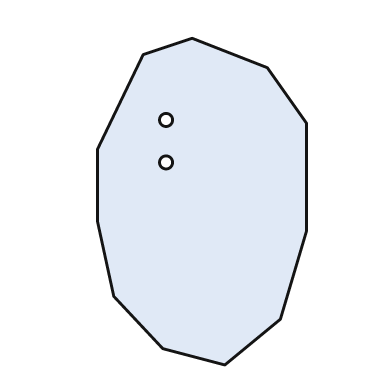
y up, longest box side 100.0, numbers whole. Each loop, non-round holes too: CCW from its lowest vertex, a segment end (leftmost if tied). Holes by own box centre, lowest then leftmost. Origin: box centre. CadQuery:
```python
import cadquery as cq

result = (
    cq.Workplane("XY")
    .moveTo(7.0, -50.0)
    .lineTo(24.0, -36.0)
    .lineTo(32.0, -9.0)
    .lineTo(32.0, 24.0)
    .lineTo(20.0, 41.0)
    .lineTo(-3.0, 50.0)
    .lineTo(-18.0, 45.0)
    .lineTo(-32.0, 16.0)
    .lineTo(-32.0, -6.0)
    .lineTo(-27.0, -29.0)
    .lineTo(-12.0, -45.0)
    .close()
    .moveTo(-11.0, 12.0)
    .circle(2.0)
    .moveTo(-11.0, 25.0)
    .circle(2.0)
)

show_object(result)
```